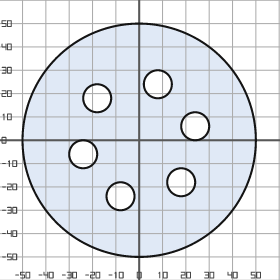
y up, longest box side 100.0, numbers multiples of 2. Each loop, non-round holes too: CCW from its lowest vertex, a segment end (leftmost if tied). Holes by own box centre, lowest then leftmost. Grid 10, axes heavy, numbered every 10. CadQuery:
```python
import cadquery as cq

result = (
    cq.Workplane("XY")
    .moveTo(0.0, 0.0)
    .circle(50.0)
    .moveTo(-8.0, -24.0)
    .circle(6.0)
    .moveTo(18.0, -18.0)
    .circle(6.0)
    .moveTo(-24.0, -6.0)
    .circle(6.0)
    .moveTo(24.0, 6.0)
    .circle(6.0)
    .moveTo(-18.0, 18.0)
    .circle(6.0)
    .moveTo(8.0, 24.0)
    .circle(6.0)
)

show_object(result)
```